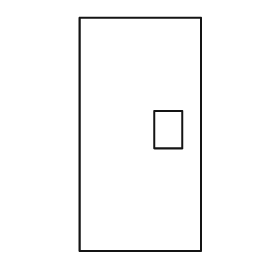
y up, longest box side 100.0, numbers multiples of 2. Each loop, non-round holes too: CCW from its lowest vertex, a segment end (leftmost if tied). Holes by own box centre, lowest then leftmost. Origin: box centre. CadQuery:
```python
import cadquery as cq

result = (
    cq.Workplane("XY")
    .moveTo(-26.0, -50.0)
    .lineTo(26.0, -50.0)
    .lineTo(26.0, 50.0)
    .lineTo(-26.0, 50.0)
    .close()
    .moveTo(6.0, -6.0)
    .lineTo(18.0, -6.0)
    .lineTo(18.0, 10.0)
    .lineTo(6.0, 10.0)
    .close()
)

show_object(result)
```